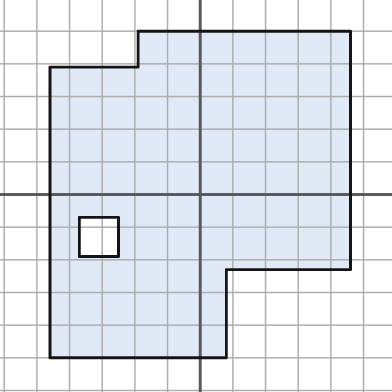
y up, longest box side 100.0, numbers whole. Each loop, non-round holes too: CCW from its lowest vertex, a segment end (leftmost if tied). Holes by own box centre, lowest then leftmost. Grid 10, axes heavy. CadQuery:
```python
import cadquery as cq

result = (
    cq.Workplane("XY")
    .moveTo(-46.0, -50.0)
    .lineTo(8.0, -50.0)
    .lineTo(8.0, -23.0)
    .lineTo(46.0, -23.0)
    .lineTo(46.0, 50.0)
    .lineTo(-19.0, 50.0)
    .lineTo(-19.0, 39.0)
    .lineTo(-46.0, 39.0)
    .close()
    .moveTo(-37.0, -19.0)
    .lineTo(-25.0, -19.0)
    .lineTo(-25.0, -7.0)
    .lineTo(-37.0, -7.0)
    .close()
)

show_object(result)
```